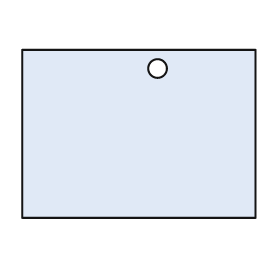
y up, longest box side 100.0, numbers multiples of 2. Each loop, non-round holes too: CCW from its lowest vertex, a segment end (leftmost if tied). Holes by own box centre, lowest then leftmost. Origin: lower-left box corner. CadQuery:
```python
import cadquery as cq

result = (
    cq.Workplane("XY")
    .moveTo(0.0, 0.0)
    .lineTo(100.0, 0.0)
    .lineTo(100.0, 72.0)
    .lineTo(0.0, 72.0)
    .close()
    .moveTo(58.0, 64.0)
    .circle(4.0)
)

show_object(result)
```